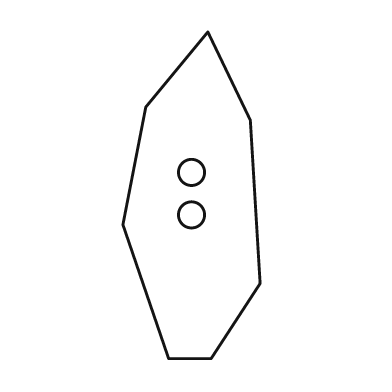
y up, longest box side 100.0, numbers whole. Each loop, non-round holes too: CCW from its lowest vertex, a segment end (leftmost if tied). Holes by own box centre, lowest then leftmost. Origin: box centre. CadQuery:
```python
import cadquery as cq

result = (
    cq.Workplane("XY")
    .moveTo(-7.0, -50.0)
    .lineTo(6.0, -50.0)
    .lineTo(21.0, -27.0)
    .lineTo(18.0, 23.0)
    .lineTo(5.0, 50.0)
    .lineTo(-14.0, 27.0)
    .lineTo(-21.0, -9.0)
    .close()
    .moveTo(0.0, -6.0)
    .circle(4.0)
    .moveTo(0.0, 7.0)
    .circle(4.0)
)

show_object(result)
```